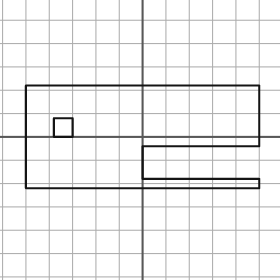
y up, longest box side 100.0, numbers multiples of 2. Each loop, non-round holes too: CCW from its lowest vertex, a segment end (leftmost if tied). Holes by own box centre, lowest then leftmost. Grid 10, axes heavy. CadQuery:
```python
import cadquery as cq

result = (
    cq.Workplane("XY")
    .moveTo(-50.0, -22.0)
    .lineTo(50.0, -22.0)
    .lineTo(50.0, -18.0)
    .lineTo(0.0, -18.0)
    .lineTo(0.0, -4.0)
    .lineTo(50.0, -4.0)
    .lineTo(50.0, 22.0)
    .lineTo(-50.0, 22.0)
    .close()
    .moveTo(-38.0, 0.0)
    .lineTo(-30.0, 0.0)
    .lineTo(-30.0, 8.0)
    .lineTo(-38.0, 8.0)
    .close()
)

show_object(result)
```